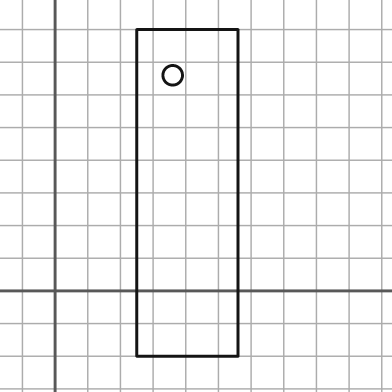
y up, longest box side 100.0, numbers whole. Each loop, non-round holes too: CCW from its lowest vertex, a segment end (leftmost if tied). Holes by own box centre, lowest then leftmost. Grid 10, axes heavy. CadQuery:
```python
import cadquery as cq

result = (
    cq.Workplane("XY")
    .moveTo(25.0, -20.0)
    .lineTo(56.0, -20.0)
    .lineTo(56.0, 80.0)
    .lineTo(25.0, 80.0)
    .close()
    .moveTo(36.0, 66.0)
    .circle(3.0)
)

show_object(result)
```